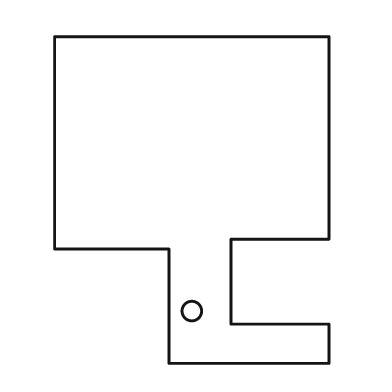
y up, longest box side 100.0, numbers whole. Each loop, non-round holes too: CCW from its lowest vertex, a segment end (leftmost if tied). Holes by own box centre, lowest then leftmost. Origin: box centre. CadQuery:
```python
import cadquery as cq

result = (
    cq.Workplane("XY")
    .moveTo(-7.0, -50.0)
    .lineTo(42.0, -50.0)
    .lineTo(42.0, -38.0)
    .lineTo(12.0, -38.0)
    .lineTo(12.0, -12.0)
    .lineTo(42.0, -12.0)
    .lineTo(42.0, 50.0)
    .lineTo(-42.0, 50.0)
    .lineTo(-42.0, -15.0)
    .lineTo(-7.0, -15.0)
    .close()
    .moveTo(0.0, -34.0)
    .circle(3.0)
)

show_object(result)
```